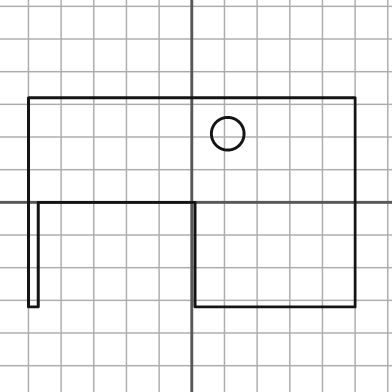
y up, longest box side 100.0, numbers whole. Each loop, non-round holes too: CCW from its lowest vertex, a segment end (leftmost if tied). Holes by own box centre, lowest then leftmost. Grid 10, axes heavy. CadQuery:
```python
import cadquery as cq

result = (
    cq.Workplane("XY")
    .moveTo(-50.0, -32.0)
    .lineTo(-47.0, -32.0)
    .lineTo(-47.0, 0.0)
    .lineTo(1.0, 0.0)
    .lineTo(1.0, -32.0)
    .lineTo(50.0, -32.0)
    .lineTo(50.0, 32.0)
    .lineTo(-50.0, 32.0)
    .close()
    .moveTo(11.0, 21.0)
    .circle(5.0)
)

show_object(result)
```